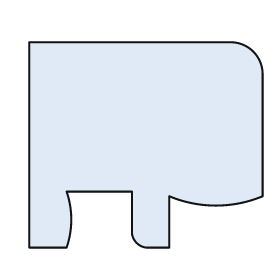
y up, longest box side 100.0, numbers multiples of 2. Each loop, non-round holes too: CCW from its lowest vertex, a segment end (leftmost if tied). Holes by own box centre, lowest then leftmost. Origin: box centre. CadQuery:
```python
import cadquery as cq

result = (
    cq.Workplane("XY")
    .moveTo(-50.0, -44.0)
    .lineTo(-34.0, -44.0)
    .threePointArc((-32.0, -32.0), (-34.0, -20.0))
    .lineTo(-6.0, -20.0)
    .lineTo(-6.0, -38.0)
    .threePointArc((-4.0, -42.0), (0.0, -44.0))
    .lineTo(10.0, -44.0)
    .lineTo(10.0, -22.0)
    .threePointArc((30.0, -26.0), (50.0, -22.0))
    .lineTo(50.0, 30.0)
    .threePointArc((46.0, 40.0), (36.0, 44.0))
    .lineTo(-50.0, 44.0)
    .close()
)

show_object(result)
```